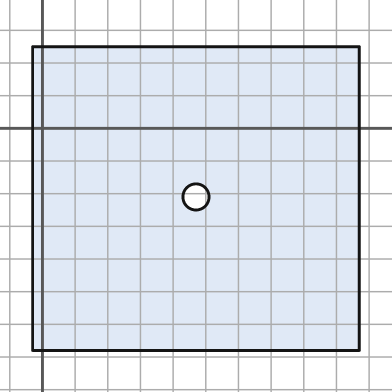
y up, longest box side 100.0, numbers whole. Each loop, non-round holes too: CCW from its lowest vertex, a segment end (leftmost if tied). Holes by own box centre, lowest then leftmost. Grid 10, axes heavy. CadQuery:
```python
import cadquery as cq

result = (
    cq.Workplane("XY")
    .moveTo(-3.0, -68.0)
    .lineTo(97.0, -68.0)
    .lineTo(97.0, 25.0)
    .lineTo(-3.0, 25.0)
    .close()
    .moveTo(47.0, -21.0)
    .circle(4.0)
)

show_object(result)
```